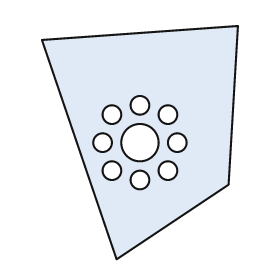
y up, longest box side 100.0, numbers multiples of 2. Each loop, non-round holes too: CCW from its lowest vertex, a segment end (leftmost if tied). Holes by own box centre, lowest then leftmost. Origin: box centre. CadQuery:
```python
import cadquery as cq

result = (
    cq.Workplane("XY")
    .moveTo(-10.0, -50.0)
    .lineTo(38.0, -18.0)
    .lineTo(42.0, 50.0)
    .lineTo(-42.0, 44.0)
    .close()
    .moveTo(0.0, -16.0)
    .circle(4.0)
    .moveTo(-12.0, -12.0)
    .circle(4.0)
    .moveTo(12.0, -12.0)
    .circle(4.0)
    .moveTo(-16.0, 0.0)
    .circle(4.0)
    .moveTo(0.0, 0.0)
    .circle(8.0)
    .moveTo(16.0, 0.0)
    .circle(4.0)
    .moveTo(-12.0, 12.0)
    .circle(4.0)
    .moveTo(12.0, 12.0)
    .circle(4.0)
    .moveTo(0.0, 16.0)
    .circle(4.0)
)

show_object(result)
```